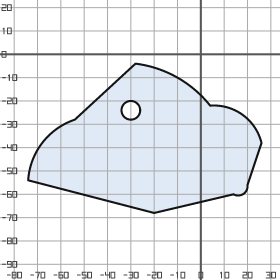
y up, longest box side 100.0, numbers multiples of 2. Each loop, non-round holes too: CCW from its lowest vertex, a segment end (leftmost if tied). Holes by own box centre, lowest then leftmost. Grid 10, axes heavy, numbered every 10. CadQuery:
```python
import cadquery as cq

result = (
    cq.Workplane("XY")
    .moveTo(-20.0, -68.0)
    .lineTo(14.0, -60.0)
    .threePointArc((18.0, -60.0), (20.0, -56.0))
    .lineTo(26.0, -38.0)
    .threePointArc((18.0, -26.0), (4.0, -22.0))
    .threePointArc((-10.0, -10.0), (-28.0, -4.0))
    .lineTo(-54.0, -28.0)
    .threePointArc((-68.0, -38.0), (-74.0, -54.0))
    .close()
    .moveTo(-30.0, -24.0)
    .circle(4.0)
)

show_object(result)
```